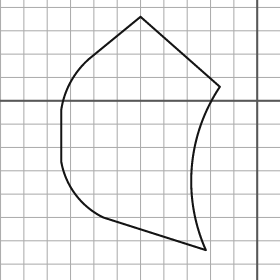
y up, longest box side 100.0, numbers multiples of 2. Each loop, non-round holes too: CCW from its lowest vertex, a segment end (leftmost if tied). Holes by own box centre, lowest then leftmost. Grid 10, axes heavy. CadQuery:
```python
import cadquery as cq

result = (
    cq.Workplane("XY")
    .moveTo(-22.0, -64.0)
    .threePointArc((-28.0, -28.0), (-16.0, 6.0))
    .lineTo(-50.0, 36.0)
    .lineTo(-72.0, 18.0)
    .threePointArc((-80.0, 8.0), (-84.0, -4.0))
    .lineTo(-84.0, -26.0)
    .threePointArc((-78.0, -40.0), (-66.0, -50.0))
    .close()
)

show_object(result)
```